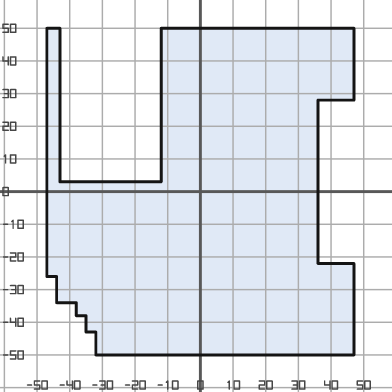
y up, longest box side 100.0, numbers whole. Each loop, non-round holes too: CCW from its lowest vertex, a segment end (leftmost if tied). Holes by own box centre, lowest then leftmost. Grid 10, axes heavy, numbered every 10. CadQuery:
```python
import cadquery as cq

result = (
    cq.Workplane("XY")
    .moveTo(-32.0, -50.0)
    .lineTo(47.0, -50.0)
    .lineTo(47.0, -22.0)
    .lineTo(36.0, -22.0)
    .lineTo(36.0, 28.0)
    .lineTo(47.0, 28.0)
    .lineTo(47.0, 50.0)
    .lineTo(-12.0, 50.0)
    .lineTo(-12.0, 3.0)
    .lineTo(-43.0, 3.0)
    .lineTo(-43.0, 50.0)
    .lineTo(-47.0, 50.0)
    .lineTo(-47.0, -26.0)
    .lineTo(-44.0, -26.0)
    .lineTo(-44.0, -34.0)
    .lineTo(-38.0, -34.0)
    .lineTo(-38.0, -38.0)
    .lineTo(-35.0, -38.0)
    .lineTo(-35.0, -43.0)
    .lineTo(-32.0, -43.0)
    .close()
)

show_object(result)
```